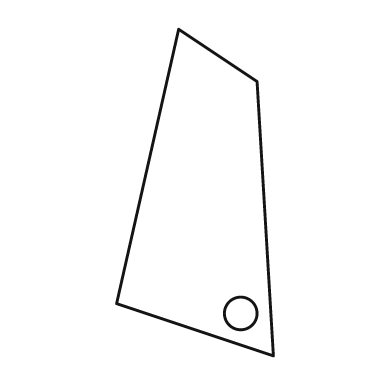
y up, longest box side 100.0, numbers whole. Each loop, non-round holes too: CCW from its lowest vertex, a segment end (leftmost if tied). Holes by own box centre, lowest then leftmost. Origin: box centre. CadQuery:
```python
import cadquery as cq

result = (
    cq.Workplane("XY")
    .moveTo(24.0, -50.0)
    .lineTo(19.0, 34.0)
    .lineTo(-5.0, 50.0)
    .lineTo(-24.0, -34.0)
    .close()
    .moveTo(14.0, -37.0)
    .circle(5.0)
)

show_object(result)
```